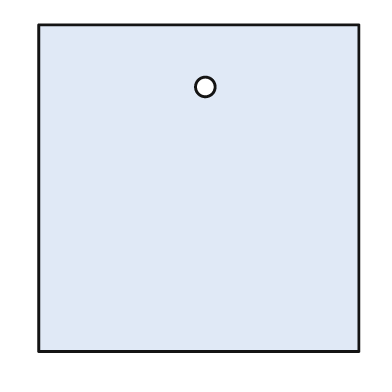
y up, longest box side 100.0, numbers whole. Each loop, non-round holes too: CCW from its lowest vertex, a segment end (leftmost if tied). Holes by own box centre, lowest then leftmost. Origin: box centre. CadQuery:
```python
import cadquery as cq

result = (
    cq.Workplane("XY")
    .moveTo(-49.0, -50.0)
    .lineTo(49.0, -50.0)
    .lineTo(49.0, 50.0)
    .lineTo(-49.0, 50.0)
    .close()
    .moveTo(2.0, 31.0)
    .circle(3.0)
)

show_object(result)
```